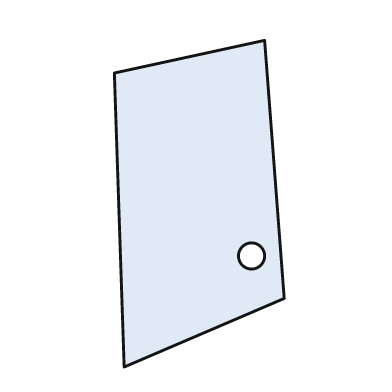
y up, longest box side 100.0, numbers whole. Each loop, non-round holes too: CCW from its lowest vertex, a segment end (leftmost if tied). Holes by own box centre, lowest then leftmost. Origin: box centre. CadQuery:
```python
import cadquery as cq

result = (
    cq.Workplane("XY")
    .moveTo(-23.0, -50.0)
    .lineTo(26.0, -29.0)
    .lineTo(20.0, 50.0)
    .lineTo(-26.0, 40.0)
    .close()
    .moveTo(16.0, -16.0)
    .circle(4.0)
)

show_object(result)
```